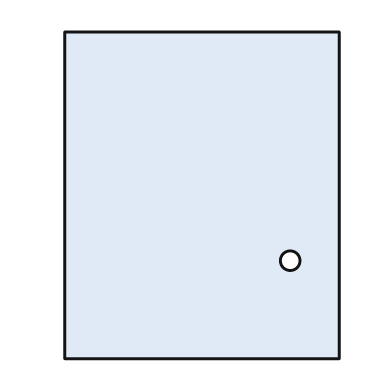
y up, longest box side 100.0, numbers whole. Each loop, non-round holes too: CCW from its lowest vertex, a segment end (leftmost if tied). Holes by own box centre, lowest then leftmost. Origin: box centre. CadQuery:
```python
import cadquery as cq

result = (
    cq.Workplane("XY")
    .moveTo(-42.0, -50.0)
    .lineTo(42.0, -50.0)
    .lineTo(42.0, 50.0)
    .lineTo(-42.0, 50.0)
    .close()
    .moveTo(27.0, -20.0)
    .circle(3.0)
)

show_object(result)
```